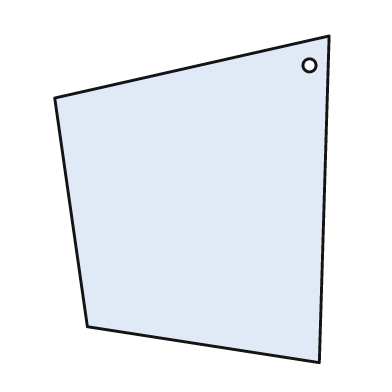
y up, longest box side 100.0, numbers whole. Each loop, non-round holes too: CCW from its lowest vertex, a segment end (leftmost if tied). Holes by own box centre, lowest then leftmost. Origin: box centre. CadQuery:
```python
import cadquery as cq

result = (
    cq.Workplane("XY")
    .moveTo(39.0, -50.0)
    .lineTo(42.0, 50.0)
    .lineTo(-42.0, 31.0)
    .lineTo(-32.0, -39.0)
    .close()
    .moveTo(36.0, 41.0)
    .circle(2.0)
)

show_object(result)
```